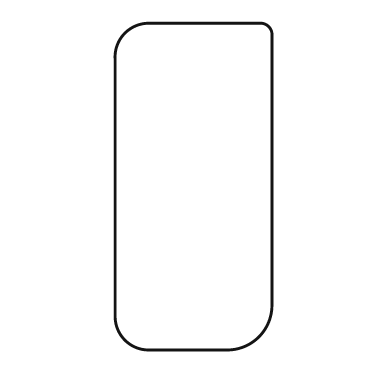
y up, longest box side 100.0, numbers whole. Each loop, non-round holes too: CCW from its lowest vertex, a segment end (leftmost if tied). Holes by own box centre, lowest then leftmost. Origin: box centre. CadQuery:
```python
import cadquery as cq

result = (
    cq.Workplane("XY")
    .moveTo(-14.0, -50.0)
    .lineTo(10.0, -50.0)
    .threePointArc((20.0, -46.0), (24.0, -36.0))
    .lineTo(24.0, 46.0)
    .threePointArc((23.0, 49.0), (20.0, 50.0))
    .lineTo(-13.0, 50.0)
    .threePointArc((-21.0, 47.0), (-24.0, 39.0))
    .lineTo(-24.0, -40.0)
    .threePointArc((-21.0, -47.0), (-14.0, -50.0))
    .close()
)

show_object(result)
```